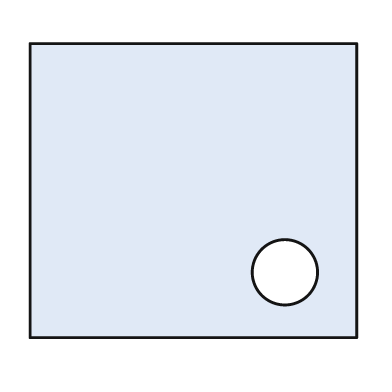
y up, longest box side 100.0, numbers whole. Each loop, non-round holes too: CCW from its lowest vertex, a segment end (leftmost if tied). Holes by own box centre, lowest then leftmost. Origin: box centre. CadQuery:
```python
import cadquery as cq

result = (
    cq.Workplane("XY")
    .moveTo(-50.0, -45.0)
    .lineTo(50.0, -45.0)
    .lineTo(50.0, 45.0)
    .lineTo(-50.0, 45.0)
    .close()
    .moveTo(28.0, -25.0)
    .circle(10.0)
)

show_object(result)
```